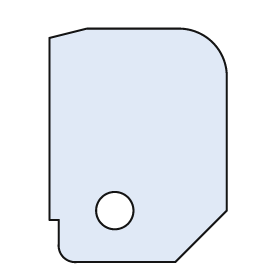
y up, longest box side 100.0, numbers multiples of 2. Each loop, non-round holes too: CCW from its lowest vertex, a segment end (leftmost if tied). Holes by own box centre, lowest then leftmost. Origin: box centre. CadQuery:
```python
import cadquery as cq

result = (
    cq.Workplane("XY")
    .moveTo(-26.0, -50.0)
    .lineTo(16.0, -50.0)
    .lineTo(38.0, -28.0)
    .lineTo(38.0, 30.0)
    .threePointArc((32.0, 44.0), (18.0, 50.0))
    .lineTo(-22.0, 50.0)
    .lineTo(-38.0, 46.0)
    .lineTo(-38.0, -32.0)
    .lineTo(-34.0, -32.0)
    .lineTo(-34.0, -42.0)
    .threePointArc((-32.0, -48.0), (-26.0, -50.0))
    .close()
    .moveTo(-10.0, -28.0)
    .circle(8.0)
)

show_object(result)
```